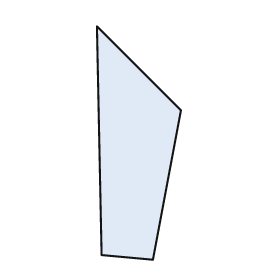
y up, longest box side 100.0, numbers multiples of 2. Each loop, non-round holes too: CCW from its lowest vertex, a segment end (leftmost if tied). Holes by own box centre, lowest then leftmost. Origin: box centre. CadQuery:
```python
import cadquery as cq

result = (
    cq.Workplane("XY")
    .moveTo(6.0, -50.0)
    .lineTo(18.0, 14.0)
    .lineTo(-18.0, 50.0)
    .lineTo(-16.0, -48.0)
    .close()
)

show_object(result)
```